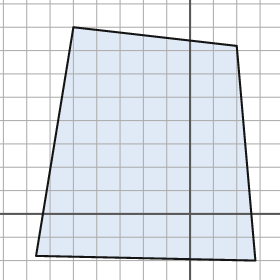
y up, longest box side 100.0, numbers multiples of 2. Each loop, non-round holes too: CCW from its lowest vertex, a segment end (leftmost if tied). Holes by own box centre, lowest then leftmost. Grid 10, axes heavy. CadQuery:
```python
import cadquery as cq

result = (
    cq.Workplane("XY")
    .moveTo(28.0, -20.0)
    .lineTo(20.0, 72.0)
    .lineTo(-50.0, 80.0)
    .lineTo(-66.0, -18.0)
    .close()
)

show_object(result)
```